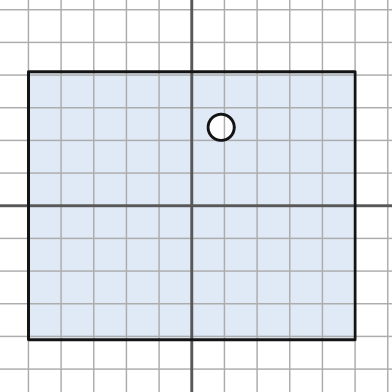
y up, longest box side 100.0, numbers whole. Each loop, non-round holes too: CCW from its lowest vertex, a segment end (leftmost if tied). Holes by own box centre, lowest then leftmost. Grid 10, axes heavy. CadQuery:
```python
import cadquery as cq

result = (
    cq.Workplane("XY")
    .moveTo(-50.0, -41.0)
    .lineTo(50.0, -41.0)
    .lineTo(50.0, 41.0)
    .lineTo(-50.0, 41.0)
    .close()
    .moveTo(9.0, 24.0)
    .circle(4.0)
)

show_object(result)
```